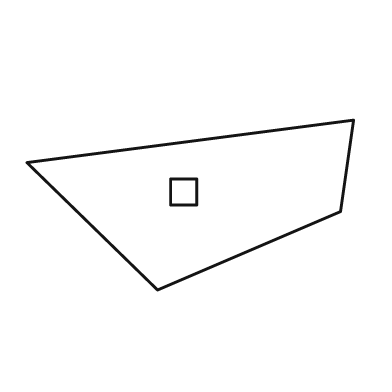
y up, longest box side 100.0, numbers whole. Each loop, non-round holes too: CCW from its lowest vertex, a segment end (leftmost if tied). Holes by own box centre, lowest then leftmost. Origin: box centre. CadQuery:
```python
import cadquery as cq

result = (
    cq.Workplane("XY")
    .moveTo(-10.0, -26.0)
    .lineTo(46.0, -2.0)
    .lineTo(50.0, 26.0)
    .lineTo(-50.0, 13.0)
    .close()
    .moveTo(-6.0, 0.0)
    .lineTo(2.0, 0.0)
    .lineTo(2.0, 8.0)
    .lineTo(-6.0, 8.0)
    .close()
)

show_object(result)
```